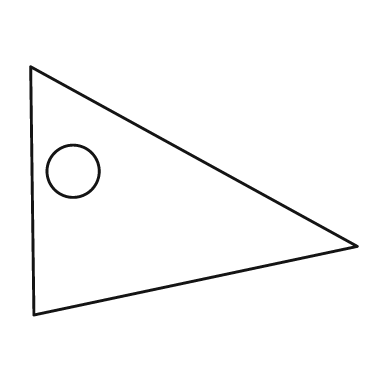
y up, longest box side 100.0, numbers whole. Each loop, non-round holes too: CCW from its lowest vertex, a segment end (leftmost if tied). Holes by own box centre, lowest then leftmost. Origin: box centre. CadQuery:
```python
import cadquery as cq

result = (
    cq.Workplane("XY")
    .moveTo(-49.0, -38.0)
    .lineTo(50.0, -17.0)
    .lineTo(-50.0, 38.0)
    .close()
    .moveTo(-37.0, 6.0)
    .circle(8.0)
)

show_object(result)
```